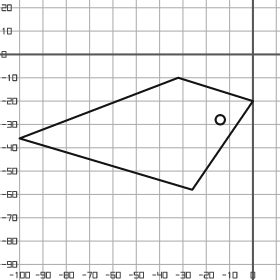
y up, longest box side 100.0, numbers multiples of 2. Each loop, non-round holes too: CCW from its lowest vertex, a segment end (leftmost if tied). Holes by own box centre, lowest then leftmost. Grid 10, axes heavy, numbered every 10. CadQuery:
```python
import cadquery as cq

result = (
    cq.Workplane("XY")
    .moveTo(-26.0, -58.0)
    .lineTo(0.0, -20.0)
    .lineTo(-32.0, -10.0)
    .lineTo(-100.0, -36.0)
    .close()
    .moveTo(-14.0, -28.0)
    .circle(2.0)
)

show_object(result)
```